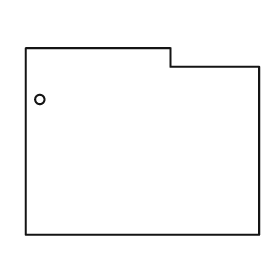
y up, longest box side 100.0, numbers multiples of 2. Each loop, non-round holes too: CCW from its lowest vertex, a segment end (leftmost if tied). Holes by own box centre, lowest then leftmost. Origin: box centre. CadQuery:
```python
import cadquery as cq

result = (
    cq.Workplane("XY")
    .moveTo(-50.0, -40.0)
    .lineTo(50.0, -40.0)
    .lineTo(50.0, 32.0)
    .lineTo(12.0, 32.0)
    .lineTo(12.0, 40.0)
    .lineTo(-50.0, 40.0)
    .close()
    .moveTo(-44.0, 18.0)
    .circle(2.0)
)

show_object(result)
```